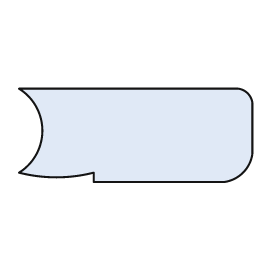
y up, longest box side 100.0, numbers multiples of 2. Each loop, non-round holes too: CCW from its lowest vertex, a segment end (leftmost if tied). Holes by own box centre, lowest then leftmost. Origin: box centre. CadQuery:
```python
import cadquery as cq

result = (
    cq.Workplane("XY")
    .moveTo(-18.0, -20.0)
    .lineTo(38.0, -20.0)
    .threePointArc((46.0, -16.0), (50.0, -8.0))
    .lineTo(50.0, 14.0)
    .threePointArc((48.0, 18.0), (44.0, 20.0))
    .lineTo(-50.0, 20.0)
    .threePointArc((-40.0, 2.0), (-50.0, -16.0))
    .threePointArc((-34.0, -18.0), (-18.0, -16.0))
    .close()
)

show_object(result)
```